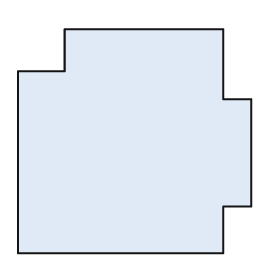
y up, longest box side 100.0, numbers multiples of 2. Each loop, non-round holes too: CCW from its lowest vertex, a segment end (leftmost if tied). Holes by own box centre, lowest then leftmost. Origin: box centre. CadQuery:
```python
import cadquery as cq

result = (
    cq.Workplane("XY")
    .moveTo(-50.0, -48.0)
    .lineTo(38.0, -48.0)
    .lineTo(38.0, -28.0)
    .lineTo(50.0, -28.0)
    .lineTo(50.0, 18.0)
    .lineTo(38.0, 18.0)
    .lineTo(38.0, 48.0)
    .lineTo(-30.0, 48.0)
    .lineTo(-30.0, 30.0)
    .lineTo(-50.0, 30.0)
    .close()
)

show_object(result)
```